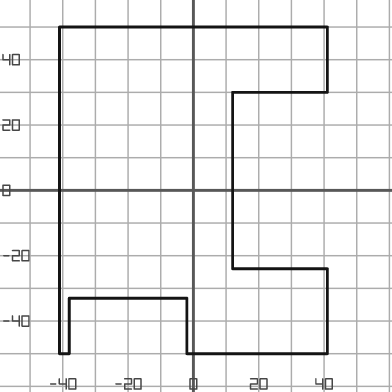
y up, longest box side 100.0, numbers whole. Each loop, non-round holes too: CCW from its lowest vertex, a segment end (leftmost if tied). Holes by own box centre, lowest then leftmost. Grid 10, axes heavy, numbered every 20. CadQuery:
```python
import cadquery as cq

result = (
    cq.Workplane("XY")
    .moveTo(-41.0, -50.0)
    .lineTo(-38.0, -50.0)
    .lineTo(-38.0, -33.0)
    .lineTo(-2.0, -33.0)
    .lineTo(-2.0, -50.0)
    .lineTo(41.0, -50.0)
    .lineTo(41.0, -24.0)
    .lineTo(12.0, -24.0)
    .lineTo(12.0, 30.0)
    .lineTo(41.0, 30.0)
    .lineTo(41.0, 50.0)
    .lineTo(-41.0, 50.0)
    .close()
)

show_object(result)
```